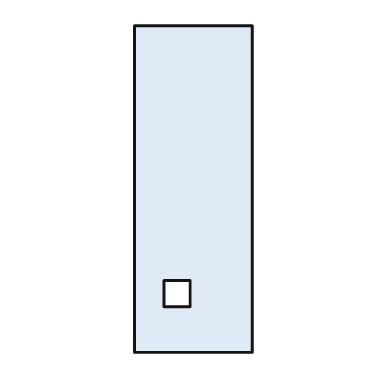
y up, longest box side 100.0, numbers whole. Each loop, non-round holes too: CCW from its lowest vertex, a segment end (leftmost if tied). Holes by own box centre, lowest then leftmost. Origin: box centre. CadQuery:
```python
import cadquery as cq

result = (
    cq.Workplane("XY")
    .moveTo(-18.0, -50.0)
    .lineTo(18.0, -50.0)
    .lineTo(18.0, 50.0)
    .lineTo(-18.0, 50.0)
    .close()
    .moveTo(-9.0, -36.0)
    .lineTo(-1.0, -36.0)
    .lineTo(-1.0, -28.0)
    .lineTo(-9.0, -28.0)
    .close()
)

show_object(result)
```